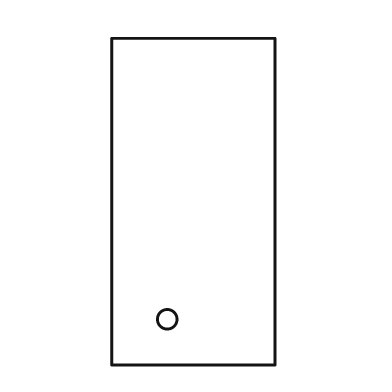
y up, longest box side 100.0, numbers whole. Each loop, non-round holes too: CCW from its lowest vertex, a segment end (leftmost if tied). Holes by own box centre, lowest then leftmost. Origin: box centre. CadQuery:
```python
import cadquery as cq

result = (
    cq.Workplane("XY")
    .moveTo(-25.0, -50.0)
    .lineTo(25.0, -50.0)
    .lineTo(25.0, 50.0)
    .lineTo(-25.0, 50.0)
    .close()
    .moveTo(-8.0, -36.0)
    .circle(3.0)
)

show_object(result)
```